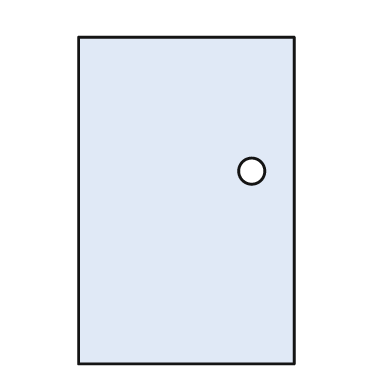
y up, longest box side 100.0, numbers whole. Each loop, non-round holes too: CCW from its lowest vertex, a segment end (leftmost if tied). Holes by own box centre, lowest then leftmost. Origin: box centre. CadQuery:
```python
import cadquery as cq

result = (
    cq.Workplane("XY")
    .moveTo(-33.0, -50.0)
    .lineTo(33.0, -50.0)
    .lineTo(33.0, 50.0)
    .lineTo(-33.0, 50.0)
    .close()
    .moveTo(20.0, 9.0)
    .circle(4.0)
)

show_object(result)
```